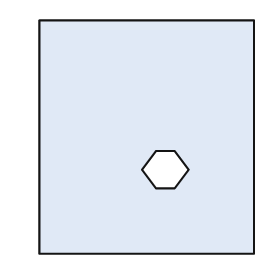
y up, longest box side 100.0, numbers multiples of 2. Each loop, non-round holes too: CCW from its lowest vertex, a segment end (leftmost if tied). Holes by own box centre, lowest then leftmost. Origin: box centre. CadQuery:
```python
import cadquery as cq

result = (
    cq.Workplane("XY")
    .moveTo(-46.0, -50.0)
    .lineTo(46.0, -50.0)
    .lineTo(46.0, 50.0)
    .lineTo(-46.0, 50.0)
    .close()
    .moveTo(4.0, -22.0)
    .lineTo(12.0, -22.0)
    .lineTo(18.0, -14.0)
    .lineTo(12.0, -6.0)
    .lineTo(4.0, -6.0)
    .lineTo(-2.0, -14.0)
    .close()
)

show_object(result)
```